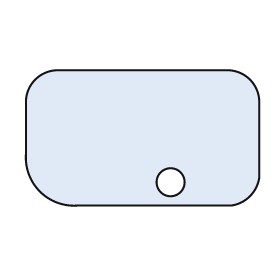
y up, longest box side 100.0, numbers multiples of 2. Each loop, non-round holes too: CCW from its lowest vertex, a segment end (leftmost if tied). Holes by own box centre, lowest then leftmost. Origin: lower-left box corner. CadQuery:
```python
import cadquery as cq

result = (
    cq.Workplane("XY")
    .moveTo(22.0, 0.0)
    .lineTo(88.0, 0.0)
    .threePointArc((96.0, 4.0), (100.0, 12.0))
    .lineTo(100.0, 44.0)
    .threePointArc((96.0, 54.0), (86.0, 58.0))
    .lineTo(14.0, 58.0)
    .threePointArc((4.0, 54.0), (0.0, 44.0))
    .lineTo(0.0, 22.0)
    .threePointArc((6.0, 6.0), (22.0, 0.0))
    .close()
    .moveTo(62.0, 10.0)
    .circle(6.0)
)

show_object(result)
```